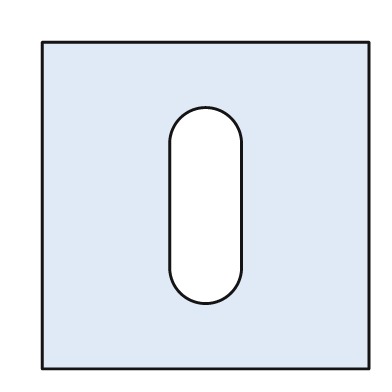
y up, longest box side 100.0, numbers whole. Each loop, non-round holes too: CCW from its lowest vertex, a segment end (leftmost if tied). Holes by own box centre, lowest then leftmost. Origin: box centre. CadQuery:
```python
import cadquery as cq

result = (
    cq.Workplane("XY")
    .moveTo(-50.0, -50.0)
    .lineTo(50.0, -50.0)
    .lineTo(50.0, 50.0)
    .lineTo(-50.0, 50.0)
    .close()
    .moveTo(-11.0, -19.0)
    .threePointArc((0.0, -30.0), (11.0, -19.0))
    .lineTo(11.0, 19.0)
    .threePointArc((0.0, 30.0), (-11.0, 19.0))
    .close()
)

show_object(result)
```